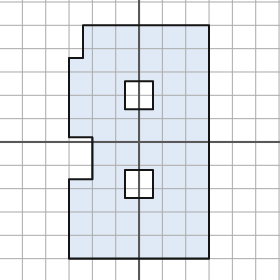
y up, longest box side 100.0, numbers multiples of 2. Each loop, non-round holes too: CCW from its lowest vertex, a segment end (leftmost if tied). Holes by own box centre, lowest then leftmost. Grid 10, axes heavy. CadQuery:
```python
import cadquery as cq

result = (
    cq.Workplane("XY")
    .moveTo(-30.0, -50.0)
    .lineTo(30.0, -50.0)
    .lineTo(30.0, 50.0)
    .lineTo(-24.0, 50.0)
    .lineTo(-24.0, 36.0)
    .lineTo(-30.0, 36.0)
    .lineTo(-30.0, 2.0)
    .lineTo(-20.0, 2.0)
    .lineTo(-20.0, -16.0)
    .lineTo(-30.0, -16.0)
    .close()
    .moveTo(-6.0, -24.0)
    .lineTo(6.0, -24.0)
    .lineTo(6.0, -12.0)
    .lineTo(-6.0, -12.0)
    .close()
    .moveTo(-6.0, 14.0)
    .lineTo(6.0, 14.0)
    .lineTo(6.0, 26.0)
    .lineTo(-6.0, 26.0)
    .close()
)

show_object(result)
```